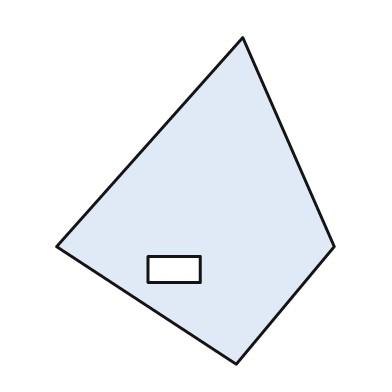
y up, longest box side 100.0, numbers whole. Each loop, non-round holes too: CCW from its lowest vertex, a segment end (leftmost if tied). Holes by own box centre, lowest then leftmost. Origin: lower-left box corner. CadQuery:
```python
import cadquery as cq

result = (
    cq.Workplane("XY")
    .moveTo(55.0, 0.0)
    .lineTo(85.0, 36.0)
    .lineTo(57.0, 100.0)
    .lineTo(0.0, 36.0)
    .close()
    .moveTo(28.0, 25.0)
    .lineTo(44.0, 25.0)
    .lineTo(44.0, 33.0)
    .lineTo(28.0, 33.0)
    .close()
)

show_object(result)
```